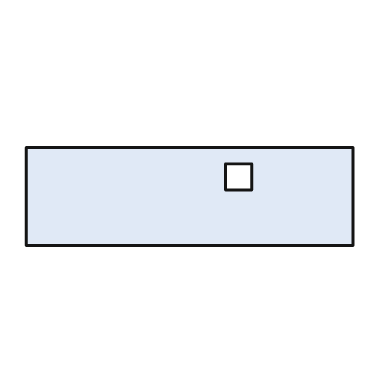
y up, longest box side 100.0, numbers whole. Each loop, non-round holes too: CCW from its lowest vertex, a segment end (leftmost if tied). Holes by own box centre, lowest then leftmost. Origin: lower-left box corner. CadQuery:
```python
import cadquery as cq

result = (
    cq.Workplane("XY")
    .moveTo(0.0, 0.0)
    .lineTo(100.0, 0.0)
    .lineTo(100.0, 30.0)
    .lineTo(0.0, 30.0)
    .close()
    .moveTo(61.0, 17.0)
    .lineTo(69.0, 17.0)
    .lineTo(69.0, 25.0)
    .lineTo(61.0, 25.0)
    .close()
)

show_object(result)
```